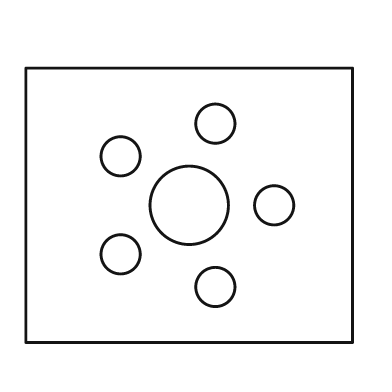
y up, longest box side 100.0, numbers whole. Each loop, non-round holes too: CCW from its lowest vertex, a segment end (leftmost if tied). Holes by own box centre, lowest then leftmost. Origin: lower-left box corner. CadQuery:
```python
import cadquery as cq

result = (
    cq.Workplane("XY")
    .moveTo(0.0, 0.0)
    .lineTo(100.0, 0.0)
    .lineTo(100.0, 84.0)
    .lineTo(0.0, 84.0)
    .close()
    .moveTo(58.0, 17.0)
    .circle(6.0)
    .moveTo(29.0, 27.0)
    .circle(6.0)
    .moveTo(50.0, 42.0)
    .circle(12.0)
    .moveTo(76.0, 42.0)
    .circle(6.0)
    .moveTo(29.0, 57.0)
    .circle(6.0)
    .moveTo(58.0, 67.0)
    .circle(6.0)
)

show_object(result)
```